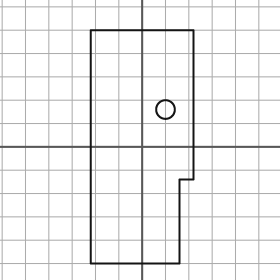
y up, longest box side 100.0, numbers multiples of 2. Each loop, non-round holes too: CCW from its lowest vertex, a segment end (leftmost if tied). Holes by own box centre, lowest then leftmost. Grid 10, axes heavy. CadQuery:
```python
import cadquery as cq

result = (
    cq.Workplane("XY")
    .moveTo(-22.0, -50.0)
    .lineTo(16.0, -50.0)
    .lineTo(16.0, -14.0)
    .lineTo(22.0, -14.0)
    .lineTo(22.0, 50.0)
    .lineTo(-22.0, 50.0)
    .close()
    .moveTo(10.0, 16.0)
    .circle(4.0)
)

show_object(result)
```